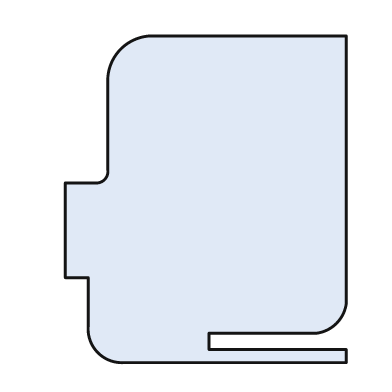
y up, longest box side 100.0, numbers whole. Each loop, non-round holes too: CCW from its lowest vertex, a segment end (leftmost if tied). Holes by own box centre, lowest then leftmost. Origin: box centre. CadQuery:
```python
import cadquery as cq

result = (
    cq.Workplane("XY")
    .moveTo(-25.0, -50.0)
    .lineTo(43.0, -50.0)
    .lineTo(43.0, -46.0)
    .lineTo(1.0, -46.0)
    .lineTo(1.0, -41.0)
    .lineTo(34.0, -41.0)
    .threePointArc((40.0, -38.0), (43.0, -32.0))
    .lineTo(43.0, 50.0)
    .lineTo(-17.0, 50.0)
    .threePointArc((-26.0, 46.0), (-30.0, 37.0))
    .lineTo(-30.0, 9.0)
    .threePointArc((-31.0, 6.0), (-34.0, 5.0))
    .lineTo(-43.0, 5.0)
    .lineTo(-43.0, -24.0)
    .lineTo(-36.0, -24.0)
    .lineTo(-36.0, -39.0)
    .threePointArc((-33.0, -47.0), (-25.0, -50.0))
    .close()
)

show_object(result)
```